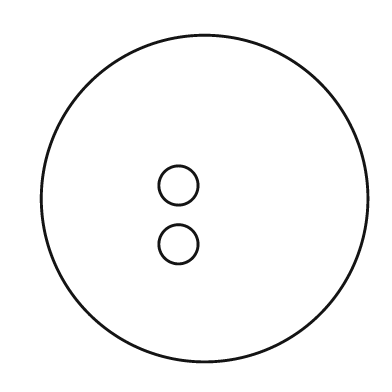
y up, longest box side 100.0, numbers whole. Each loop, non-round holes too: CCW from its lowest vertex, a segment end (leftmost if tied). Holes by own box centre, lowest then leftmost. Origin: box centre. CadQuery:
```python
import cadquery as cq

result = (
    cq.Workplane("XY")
    .moveTo(0.0, 0.0)
    .circle(50.0)
    .moveTo(-8.0, -14.0)
    .circle(6.0)
    .moveTo(-8.0, 4.0)
    .circle(6.0)
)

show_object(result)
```